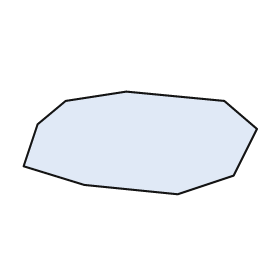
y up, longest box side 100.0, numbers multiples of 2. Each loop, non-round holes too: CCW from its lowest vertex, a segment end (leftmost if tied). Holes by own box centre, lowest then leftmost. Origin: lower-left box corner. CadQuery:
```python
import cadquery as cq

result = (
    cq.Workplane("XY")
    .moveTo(66.0, 0.0)
    .lineTo(90.0, 8.0)
    .lineTo(100.0, 28.0)
    .lineTo(86.0, 40.0)
    .lineTo(44.0, 44.0)
    .lineTo(18.0, 40.0)
    .lineTo(6.0, 30.0)
    .lineTo(0.0, 12.0)
    .lineTo(26.0, 4.0)
    .close()
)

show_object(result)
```